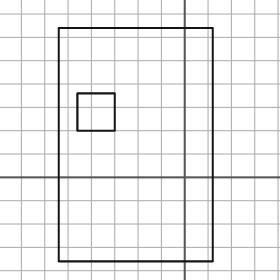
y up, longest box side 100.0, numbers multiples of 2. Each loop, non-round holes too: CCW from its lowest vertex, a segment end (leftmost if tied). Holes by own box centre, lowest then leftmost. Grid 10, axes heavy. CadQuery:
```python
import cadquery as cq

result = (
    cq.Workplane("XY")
    .moveTo(-54.0, -36.0)
    .lineTo(12.0, -36.0)
    .lineTo(12.0, 64.0)
    .lineTo(-54.0, 64.0)
    .close()
    .moveTo(-46.0, 20.0)
    .lineTo(-30.0, 20.0)
    .lineTo(-30.0, 36.0)
    .lineTo(-46.0, 36.0)
    .close()
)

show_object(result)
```